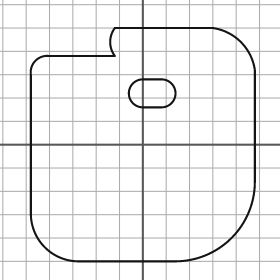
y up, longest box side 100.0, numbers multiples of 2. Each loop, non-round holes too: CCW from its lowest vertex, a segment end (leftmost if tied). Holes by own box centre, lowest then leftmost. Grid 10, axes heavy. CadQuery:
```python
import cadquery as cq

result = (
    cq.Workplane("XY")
    .moveTo(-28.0, -50.0)
    .lineTo(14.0, -50.0)
    .threePointArc((38.0, -40.0), (48.0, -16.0))
    .lineTo(48.0, 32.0)
    .threePointArc((42.0, 44.0), (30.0, 50.0))
    .lineTo(-12.0, 50.0)
    .threePointArc((-14.0, 44.0), (-12.0, 38.0))
    .lineTo(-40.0, 38.0)
    .threePointArc((-46.0, 36.0), (-48.0, 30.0))
    .lineTo(-48.0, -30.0)
    .threePointArc((-42.0, -44.0), (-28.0, -50.0))
    .close()
    .moveTo(0.0, 16.0)
    .lineTo(8.0, 16.0)
    .threePointArc((14.0, 22.0), (8.0, 28.0))
    .lineTo(0.0, 28.0)
    .threePointArc((-6.0, 22.0), (0.0, 16.0))
    .close()
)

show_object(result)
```